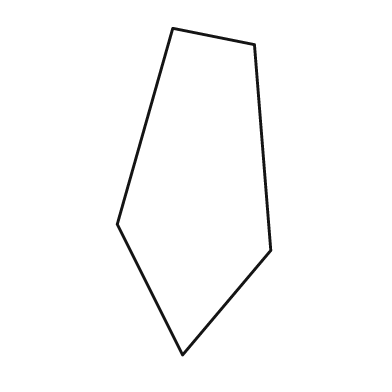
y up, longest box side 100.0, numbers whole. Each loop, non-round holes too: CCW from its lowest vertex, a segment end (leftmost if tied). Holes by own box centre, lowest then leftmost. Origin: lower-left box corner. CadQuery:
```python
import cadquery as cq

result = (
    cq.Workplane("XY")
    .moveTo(20.0, 0.0)
    .lineTo(47.0, 32.0)
    .lineTo(42.0, 95.0)
    .lineTo(17.0, 100.0)
    .lineTo(0.0, 40.0)
    .close()
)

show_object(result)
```